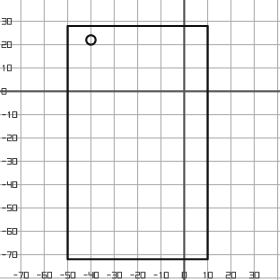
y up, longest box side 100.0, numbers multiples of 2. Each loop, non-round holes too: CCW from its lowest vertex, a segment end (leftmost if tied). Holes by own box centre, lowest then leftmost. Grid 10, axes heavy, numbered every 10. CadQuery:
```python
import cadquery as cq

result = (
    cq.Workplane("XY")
    .moveTo(-50.0, -72.0)
    .lineTo(10.0, -72.0)
    .lineTo(10.0, 28.0)
    .lineTo(-50.0, 28.0)
    .close()
    .moveTo(-40.0, 22.0)
    .circle(2.0)
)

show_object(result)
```